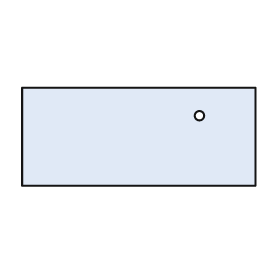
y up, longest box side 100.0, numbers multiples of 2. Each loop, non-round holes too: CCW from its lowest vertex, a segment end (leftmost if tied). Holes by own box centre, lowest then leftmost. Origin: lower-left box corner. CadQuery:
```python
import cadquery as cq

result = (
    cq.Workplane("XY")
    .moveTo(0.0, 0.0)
    .lineTo(100.0, 0.0)
    .lineTo(100.0, 42.0)
    .lineTo(0.0, 42.0)
    .close()
    .moveTo(76.0, 30.0)
    .circle(2.0)
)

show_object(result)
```